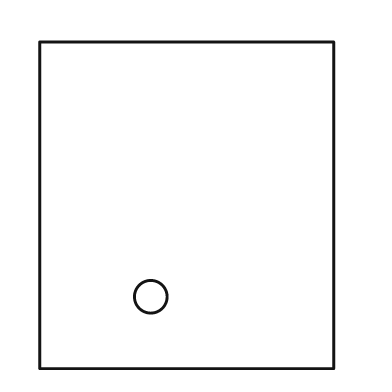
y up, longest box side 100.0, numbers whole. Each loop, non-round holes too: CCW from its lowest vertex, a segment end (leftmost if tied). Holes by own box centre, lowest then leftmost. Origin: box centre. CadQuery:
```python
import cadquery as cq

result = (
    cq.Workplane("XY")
    .moveTo(-45.0, -50.0)
    .lineTo(45.0, -50.0)
    .lineTo(45.0, 50.0)
    .lineTo(-45.0, 50.0)
    .close()
    .moveTo(-11.0, -28.0)
    .circle(5.0)
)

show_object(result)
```